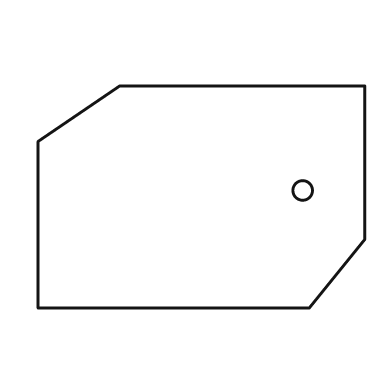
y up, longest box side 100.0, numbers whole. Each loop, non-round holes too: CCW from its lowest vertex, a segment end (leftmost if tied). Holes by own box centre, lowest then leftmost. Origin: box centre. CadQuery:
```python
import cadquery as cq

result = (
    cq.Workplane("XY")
    .moveTo(-50.0, -34.0)
    .lineTo(33.0, -34.0)
    .lineTo(50.0, -13.0)
    .lineTo(50.0, 34.0)
    .lineTo(-25.0, 34.0)
    .lineTo(-50.0, 17.0)
    .close()
    .moveTo(31.0, 2.0)
    .circle(3.0)
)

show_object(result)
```